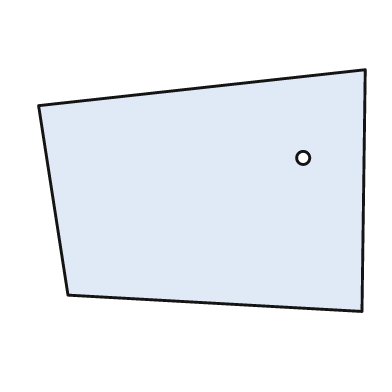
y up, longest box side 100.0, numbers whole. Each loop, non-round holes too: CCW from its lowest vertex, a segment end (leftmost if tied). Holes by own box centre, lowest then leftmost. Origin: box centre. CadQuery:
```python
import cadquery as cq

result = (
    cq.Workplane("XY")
    .moveTo(49.0, -37.0)
    .lineTo(50.0, 37.0)
    .lineTo(-50.0, 26.0)
    .lineTo(-41.0, -32.0)
    .close()
    .moveTo(31.0, 10.0)
    .circle(2.0)
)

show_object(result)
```